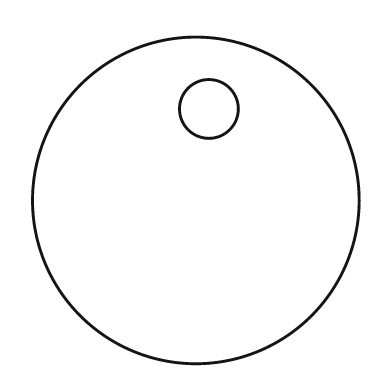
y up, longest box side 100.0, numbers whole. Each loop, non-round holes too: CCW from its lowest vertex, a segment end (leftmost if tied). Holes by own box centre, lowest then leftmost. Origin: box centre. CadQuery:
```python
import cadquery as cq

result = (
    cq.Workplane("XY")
    .moveTo(0.0, 0.0)
    .circle(50.0)
    .moveTo(4.0, 28.0)
    .circle(9.0)
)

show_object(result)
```